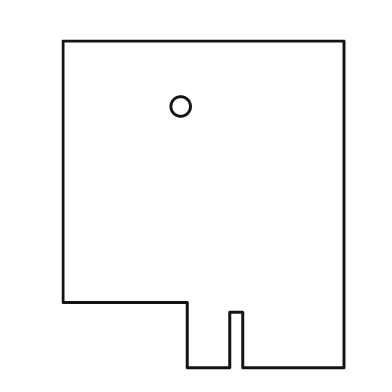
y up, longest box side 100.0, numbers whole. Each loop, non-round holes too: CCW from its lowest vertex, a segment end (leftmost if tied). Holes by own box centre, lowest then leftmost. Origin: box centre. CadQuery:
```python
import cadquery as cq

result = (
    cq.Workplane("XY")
    .moveTo(-5.0, -50.0)
    .lineTo(8.0, -50.0)
    .lineTo(8.0, -33.0)
    .lineTo(12.0, -33.0)
    .lineTo(12.0, -50.0)
    .lineTo(43.0, -50.0)
    .lineTo(43.0, 50.0)
    .lineTo(-43.0, 50.0)
    .lineTo(-43.0, -30.0)
    .lineTo(-5.0, -30.0)
    .close()
    .moveTo(-7.0, 30.0)
    .circle(3.0)
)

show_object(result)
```